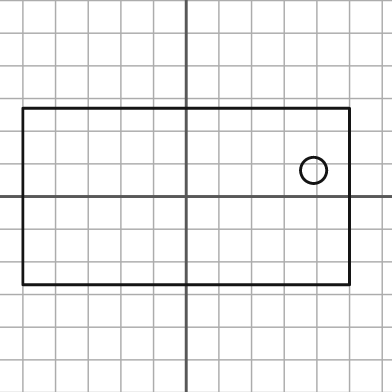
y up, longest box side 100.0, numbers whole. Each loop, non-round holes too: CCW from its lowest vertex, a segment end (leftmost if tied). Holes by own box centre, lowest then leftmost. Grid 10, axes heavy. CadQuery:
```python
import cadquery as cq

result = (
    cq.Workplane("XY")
    .moveTo(-50.0, -27.0)
    .lineTo(50.0, -27.0)
    .lineTo(50.0, 27.0)
    .lineTo(-50.0, 27.0)
    .close()
    .moveTo(39.0, 8.0)
    .circle(4.0)
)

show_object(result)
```